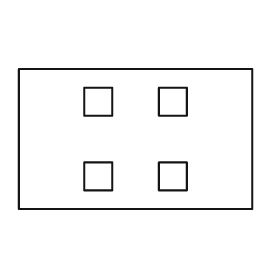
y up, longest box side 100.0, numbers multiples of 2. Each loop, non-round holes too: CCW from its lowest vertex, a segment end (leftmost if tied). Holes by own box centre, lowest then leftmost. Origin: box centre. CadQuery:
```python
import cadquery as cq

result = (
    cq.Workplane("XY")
    .moveTo(-50.0, -30.0)
    .lineTo(50.0, -30.0)
    .lineTo(50.0, 30.0)
    .lineTo(-50.0, 30.0)
    .close()
    .moveTo(-22.0, -22.0)
    .lineTo(-10.0, -22.0)
    .lineTo(-10.0, -10.0)
    .lineTo(-22.0, -10.0)
    .close()
    .moveTo(10.0, -22.0)
    .lineTo(22.0, -22.0)
    .lineTo(22.0, -10.0)
    .lineTo(10.0, -10.0)
    .close()
    .moveTo(-22.0, 10.0)
    .lineTo(-10.0, 10.0)
    .lineTo(-10.0, 22.0)
    .lineTo(-22.0, 22.0)
    .close()
    .moveTo(10.0, 10.0)
    .lineTo(22.0, 10.0)
    .lineTo(22.0, 22.0)
    .lineTo(10.0, 22.0)
    .close()
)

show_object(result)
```